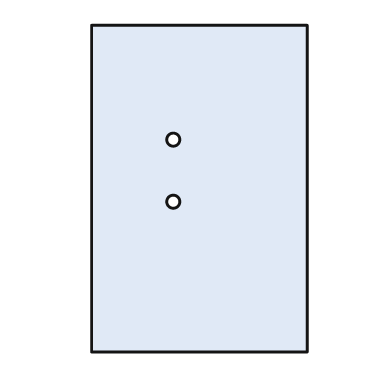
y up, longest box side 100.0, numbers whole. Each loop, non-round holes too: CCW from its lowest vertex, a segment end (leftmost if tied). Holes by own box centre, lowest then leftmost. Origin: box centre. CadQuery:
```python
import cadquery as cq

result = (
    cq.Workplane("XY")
    .moveTo(-33.0, -50.0)
    .lineTo(33.0, -50.0)
    .lineTo(33.0, 50.0)
    .lineTo(-33.0, 50.0)
    .close()
    .moveTo(-8.0, -4.0)
    .circle(2.0)
    .moveTo(-8.0, 15.0)
    .circle(2.0)
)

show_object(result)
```